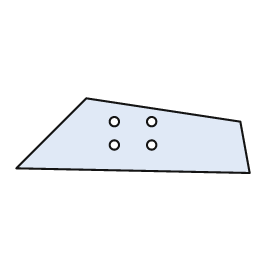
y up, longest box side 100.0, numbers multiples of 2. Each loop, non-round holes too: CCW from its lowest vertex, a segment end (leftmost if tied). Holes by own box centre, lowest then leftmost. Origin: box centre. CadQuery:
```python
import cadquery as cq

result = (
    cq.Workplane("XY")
    .moveTo(50.0, -16.0)
    .lineTo(46.0, 6.0)
    .lineTo(-20.0, 16.0)
    .lineTo(-50.0, -14.0)
    .close()
    .moveTo(-8.0, -4.0)
    .circle(2.0)
    .moveTo(8.0, -4.0)
    .circle(2.0)
    .moveTo(-8.0, 6.0)
    .circle(2.0)
    .moveTo(8.0, 6.0)
    .circle(2.0)
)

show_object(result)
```